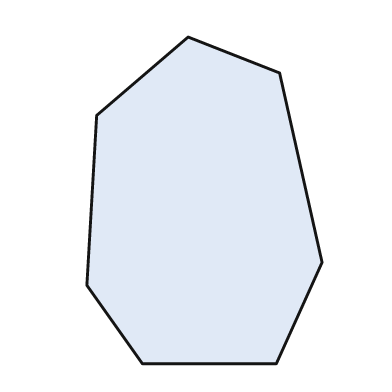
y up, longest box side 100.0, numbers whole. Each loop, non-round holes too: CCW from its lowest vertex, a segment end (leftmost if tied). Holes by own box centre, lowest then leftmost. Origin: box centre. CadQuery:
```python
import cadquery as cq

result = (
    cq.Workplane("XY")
    .moveTo(-19.0, -50.0)
    .lineTo(22.0, -50.0)
    .lineTo(36.0, -19.0)
    .lineTo(23.0, 39.0)
    .lineTo(-5.0, 50.0)
    .lineTo(-33.0, 26.0)
    .lineTo(-36.0, -26.0)
    .close()
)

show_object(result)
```